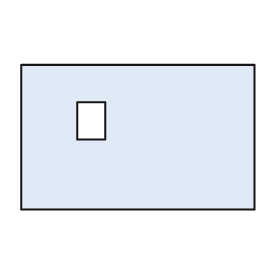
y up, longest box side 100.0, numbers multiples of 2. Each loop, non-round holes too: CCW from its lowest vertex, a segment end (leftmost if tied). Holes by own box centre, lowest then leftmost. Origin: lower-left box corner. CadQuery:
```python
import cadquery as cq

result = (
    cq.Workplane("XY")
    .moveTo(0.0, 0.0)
    .lineTo(100.0, 0.0)
    .lineTo(100.0, 62.0)
    .lineTo(0.0, 62.0)
    .close()
    .moveTo(24.0, 30.0)
    .lineTo(36.0, 30.0)
    .lineTo(36.0, 46.0)
    .lineTo(24.0, 46.0)
    .close()
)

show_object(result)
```